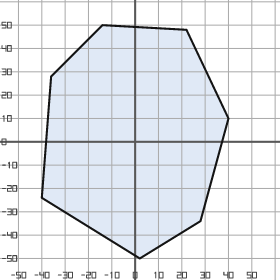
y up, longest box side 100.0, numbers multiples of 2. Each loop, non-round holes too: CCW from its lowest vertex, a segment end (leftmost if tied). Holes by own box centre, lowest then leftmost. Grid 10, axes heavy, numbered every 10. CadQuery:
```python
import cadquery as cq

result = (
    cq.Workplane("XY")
    .moveTo(2.0, -50.0)
    .lineTo(28.0, -34.0)
    .lineTo(40.0, 10.0)
    .lineTo(22.0, 48.0)
    .lineTo(-14.0, 50.0)
    .lineTo(-36.0, 28.0)
    .lineTo(-40.0, -24.0)
    .close()
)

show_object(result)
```